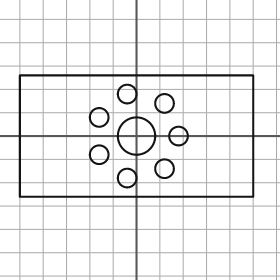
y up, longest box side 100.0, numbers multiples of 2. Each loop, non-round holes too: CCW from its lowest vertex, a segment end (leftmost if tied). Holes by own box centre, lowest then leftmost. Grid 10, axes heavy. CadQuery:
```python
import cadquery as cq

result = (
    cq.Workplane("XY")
    .moveTo(-50.0, -26.0)
    .lineTo(50.0, -26.0)
    .lineTo(50.0, 26.0)
    .lineTo(-50.0, 26.0)
    .close()
    .moveTo(-4.0, -18.0)
    .circle(4.0)
    .moveTo(12.0, -14.0)
    .circle(4.0)
    .moveTo(-16.0, -8.0)
    .circle(4.0)
    .moveTo(0.0, 0.0)
    .circle(8.0)
    .moveTo(18.0, 0.0)
    .circle(4.0)
    .moveTo(-16.0, 8.0)
    .circle(4.0)
    .moveTo(12.0, 14.0)
    .circle(4.0)
    .moveTo(-4.0, 18.0)
    .circle(4.0)
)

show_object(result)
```